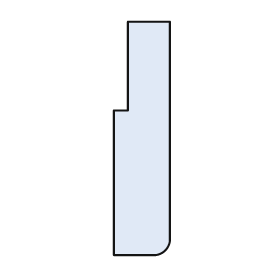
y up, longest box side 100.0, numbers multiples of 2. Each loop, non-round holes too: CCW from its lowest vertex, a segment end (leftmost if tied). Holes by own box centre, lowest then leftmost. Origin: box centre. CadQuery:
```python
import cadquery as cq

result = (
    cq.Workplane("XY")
    .moveTo(-12.0, -50.0)
    .lineTo(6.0, -50.0)
    .threePointArc((10.0, -48.0), (12.0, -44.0))
    .lineTo(12.0, 50.0)
    .lineTo(-6.0, 50.0)
    .lineTo(-6.0, 12.0)
    .lineTo(-12.0, 12.0)
    .close()
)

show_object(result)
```